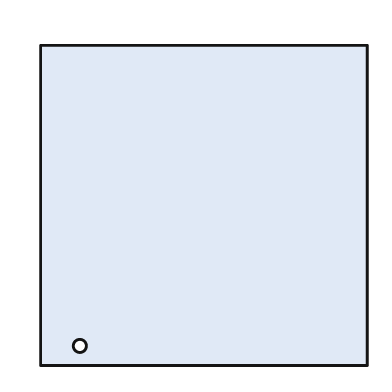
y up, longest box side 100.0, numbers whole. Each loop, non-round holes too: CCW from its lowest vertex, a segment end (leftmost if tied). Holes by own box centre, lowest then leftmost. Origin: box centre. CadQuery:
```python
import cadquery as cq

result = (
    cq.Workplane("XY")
    .moveTo(-50.0, -49.0)
    .lineTo(50.0, -49.0)
    .lineTo(50.0, 49.0)
    .lineTo(-50.0, 49.0)
    .close()
    .moveTo(-38.0, -43.0)
    .circle(2.0)
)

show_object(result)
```